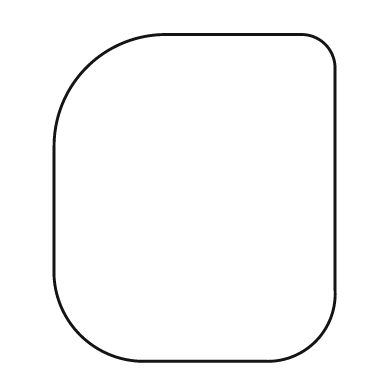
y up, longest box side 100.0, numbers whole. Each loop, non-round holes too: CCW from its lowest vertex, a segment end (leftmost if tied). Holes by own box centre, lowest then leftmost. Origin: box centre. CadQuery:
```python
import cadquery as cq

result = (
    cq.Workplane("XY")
    .moveTo(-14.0, -50.0)
    .lineTo(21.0, -50.0)
    .threePointArc((37.0, -44.0), (43.0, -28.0))
    .lineTo(43.0, 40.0)
    .threePointArc((40.0, 47.0), (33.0, 50.0))
    .lineTo(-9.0, 50.0)
    .threePointArc((-33.0, 40.0), (-43.0, 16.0))
    .lineTo(-43.0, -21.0)
    .threePointArc((-35.0, -42.0), (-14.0, -50.0))
    .close()
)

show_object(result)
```